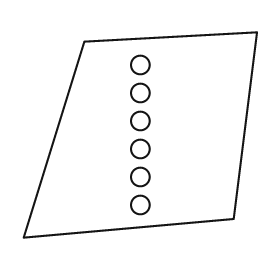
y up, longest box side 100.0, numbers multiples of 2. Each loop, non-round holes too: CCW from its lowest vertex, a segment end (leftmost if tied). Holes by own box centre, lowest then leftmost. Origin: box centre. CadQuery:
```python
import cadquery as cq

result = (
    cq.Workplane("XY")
    .moveTo(-50.0, -44.0)
    .lineTo(40.0, -36.0)
    .lineTo(50.0, 44.0)
    .lineTo(-24.0, 40.0)
    .close()
    .moveTo(0.0, -30.0)
    .circle(4.0)
    .moveTo(0.0, -18.0)
    .circle(4.0)
    .moveTo(0.0, -6.0)
    .circle(4.0)
    .moveTo(0.0, 6.0)
    .circle(4.0)
    .moveTo(0.0, 18.0)
    .circle(4.0)
    .moveTo(0.0, 30.0)
    .circle(4.0)
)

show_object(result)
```